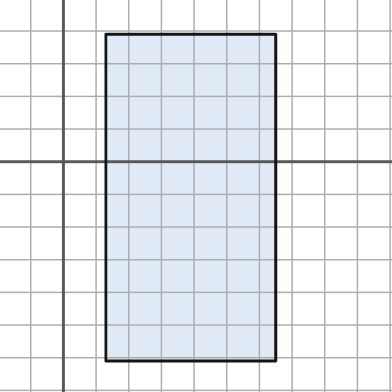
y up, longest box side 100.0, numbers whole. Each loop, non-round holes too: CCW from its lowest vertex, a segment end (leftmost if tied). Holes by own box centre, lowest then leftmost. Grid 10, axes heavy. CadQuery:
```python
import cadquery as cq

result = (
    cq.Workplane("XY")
    .moveTo(13.0, -61.0)
    .lineTo(65.0, -61.0)
    .lineTo(65.0, 39.0)
    .lineTo(13.0, 39.0)
    .close()
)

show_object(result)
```